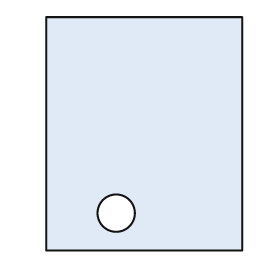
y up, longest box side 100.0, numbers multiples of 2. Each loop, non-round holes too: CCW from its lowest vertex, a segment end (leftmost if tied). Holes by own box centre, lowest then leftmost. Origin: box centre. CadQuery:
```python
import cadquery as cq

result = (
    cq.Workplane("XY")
    .moveTo(-42.0, -50.0)
    .lineTo(42.0, -50.0)
    .lineTo(42.0, 50.0)
    .lineTo(-42.0, 50.0)
    .close()
    .moveTo(-12.0, -34.0)
    .circle(8.0)
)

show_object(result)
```